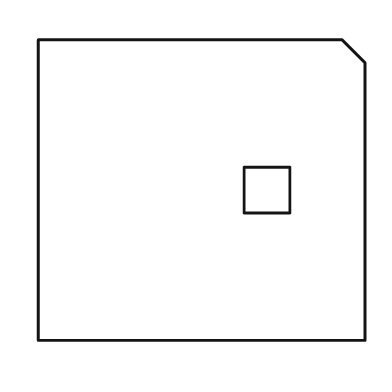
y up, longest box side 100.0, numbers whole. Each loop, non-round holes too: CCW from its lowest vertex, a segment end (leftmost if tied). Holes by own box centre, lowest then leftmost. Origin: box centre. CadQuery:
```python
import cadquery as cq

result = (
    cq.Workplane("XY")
    .moveTo(-50.0, -46.0)
    .lineTo(50.0, -46.0)
    .lineTo(50.0, 39.0)
    .lineTo(43.0, 46.0)
    .lineTo(-50.0, 46.0)
    .close()
    .moveTo(13.0, -7.0)
    .lineTo(27.0, -7.0)
    .lineTo(27.0, 7.0)
    .lineTo(13.0, 7.0)
    .close()
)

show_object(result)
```